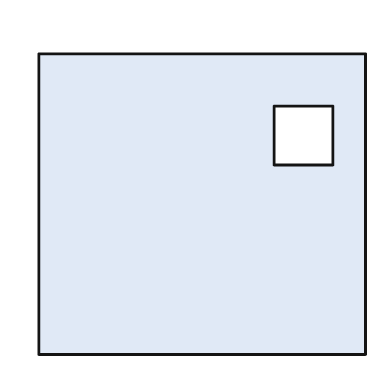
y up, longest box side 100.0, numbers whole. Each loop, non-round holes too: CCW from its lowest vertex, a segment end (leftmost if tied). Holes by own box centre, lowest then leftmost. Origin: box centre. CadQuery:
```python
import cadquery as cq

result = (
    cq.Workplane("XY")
    .moveTo(-50.0, -46.0)
    .lineTo(50.0, -46.0)
    .lineTo(50.0, 46.0)
    .lineTo(-50.0, 46.0)
    .close()
    .moveTo(22.0, 12.0)
    .lineTo(40.0, 12.0)
    .lineTo(40.0, 30.0)
    .lineTo(22.0, 30.0)
    .close()
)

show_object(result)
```